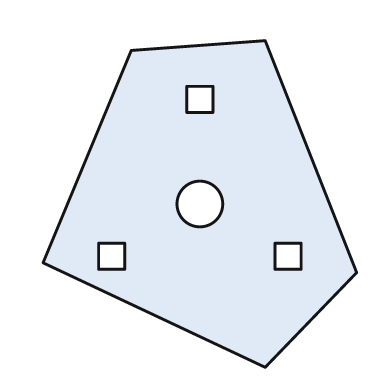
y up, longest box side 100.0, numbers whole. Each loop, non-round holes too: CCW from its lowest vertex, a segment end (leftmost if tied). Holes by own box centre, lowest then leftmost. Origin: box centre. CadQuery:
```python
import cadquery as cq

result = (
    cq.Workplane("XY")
    .moveTo(20.0, -50.0)
    .lineTo(48.0, -21.0)
    .lineTo(20.0, 50.0)
    .lineTo(-21.0, 47.0)
    .lineTo(-48.0, -18.0)
    .close()
    .moveTo(-31.0, -20.0)
    .lineTo(-23.0, -20.0)
    .lineTo(-23.0, -12.0)
    .lineTo(-31.0, -12.0)
    .close()
    .moveTo(23.0, -20.0)
    .lineTo(31.0, -20.0)
    .lineTo(31.0, -12.0)
    .lineTo(23.0, -12.0)
    .close()
    .moveTo(0.0, 0.0)
    .circle(7.0)
    .moveTo(-4.0, 28.0)
    .lineTo(4.0, 28.0)
    .lineTo(4.0, 36.0)
    .lineTo(-4.0, 36.0)
    .close()
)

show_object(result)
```